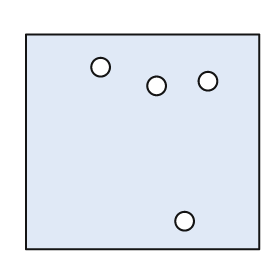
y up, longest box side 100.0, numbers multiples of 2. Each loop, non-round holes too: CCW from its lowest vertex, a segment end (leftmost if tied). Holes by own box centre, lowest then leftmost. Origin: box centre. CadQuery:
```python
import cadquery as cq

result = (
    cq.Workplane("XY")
    .moveTo(-50.0, -46.0)
    .lineTo(50.0, -46.0)
    .lineTo(50.0, 46.0)
    .lineTo(-50.0, 46.0)
    .close()
    .moveTo(18.0, -34.0)
    .circle(4.0)
    .moveTo(6.0, 24.0)
    .circle(4.0)
    .moveTo(28.0, 26.0)
    .circle(4.0)
    .moveTo(-18.0, 32.0)
    .circle(4.0)
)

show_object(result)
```